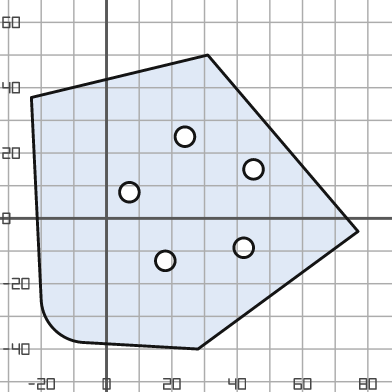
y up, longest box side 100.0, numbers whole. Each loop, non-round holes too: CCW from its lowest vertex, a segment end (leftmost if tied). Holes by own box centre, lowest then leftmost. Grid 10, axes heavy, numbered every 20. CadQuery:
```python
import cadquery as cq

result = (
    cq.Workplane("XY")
    .moveTo(28.0, -40.0)
    .lineTo(77.0, -4.0)
    .lineTo(31.0, 50.0)
    .lineTo(-23.0, 37.0)
    .lineTo(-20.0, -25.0)
    .threePointArc((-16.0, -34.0), (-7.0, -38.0))
    .close()
    .moveTo(18.0, -13.0)
    .circle(3.0)
    .moveTo(42.0, -9.0)
    .circle(3.0)
    .moveTo(7.0, 8.0)
    .circle(3.0)
    .moveTo(45.0, 15.0)
    .circle(3.0)
    .moveTo(24.0, 25.0)
    .circle(3.0)
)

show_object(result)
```